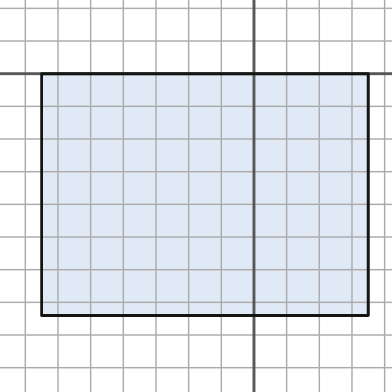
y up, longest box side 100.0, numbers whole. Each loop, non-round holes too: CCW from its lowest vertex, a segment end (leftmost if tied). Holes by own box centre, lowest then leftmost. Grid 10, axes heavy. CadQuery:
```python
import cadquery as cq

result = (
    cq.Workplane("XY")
    .moveTo(-65.0, -74.0)
    .lineTo(35.0, -74.0)
    .lineTo(35.0, 0.0)
    .lineTo(-65.0, 0.0)
    .close()
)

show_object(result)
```